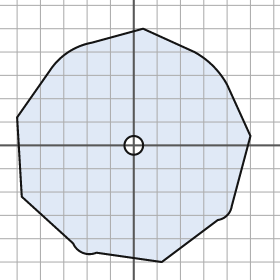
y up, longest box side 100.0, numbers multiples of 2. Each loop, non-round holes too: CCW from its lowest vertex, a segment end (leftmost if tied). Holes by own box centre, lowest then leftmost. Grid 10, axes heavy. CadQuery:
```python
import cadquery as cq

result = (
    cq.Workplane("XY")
    .moveTo(12.0, -50.0)
    .lineTo(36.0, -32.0)
    .threePointArc((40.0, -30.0), (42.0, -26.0))
    .lineTo(50.0, 4.0)
    .lineTo(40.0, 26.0)
    .threePointArc((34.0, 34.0), (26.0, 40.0))
    .lineTo(4.0, 50.0)
    .lineTo(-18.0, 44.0)
    .threePointArc((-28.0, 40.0), (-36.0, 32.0))
    .lineTo(-50.0, 12.0)
    .lineTo(-48.0, -22.0)
    .lineTo(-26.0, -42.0)
    .threePointArc((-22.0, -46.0), (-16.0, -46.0))
    .close()
    .moveTo(0.0, 0.0)
    .circle(4.0)
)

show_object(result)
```